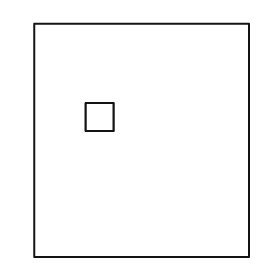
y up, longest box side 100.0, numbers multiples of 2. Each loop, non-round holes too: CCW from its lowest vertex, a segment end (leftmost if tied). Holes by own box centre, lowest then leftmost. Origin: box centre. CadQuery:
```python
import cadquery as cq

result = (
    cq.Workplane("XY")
    .moveTo(-46.0, -50.0)
    .lineTo(46.0, -50.0)
    .lineTo(46.0, 50.0)
    .lineTo(-46.0, 50.0)
    .close()
    .moveTo(-24.0, 4.0)
    .lineTo(-12.0, 4.0)
    .lineTo(-12.0, 16.0)
    .lineTo(-24.0, 16.0)
    .close()
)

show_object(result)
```